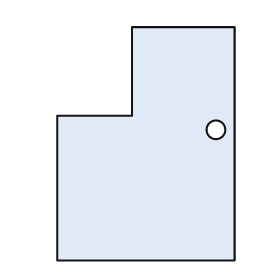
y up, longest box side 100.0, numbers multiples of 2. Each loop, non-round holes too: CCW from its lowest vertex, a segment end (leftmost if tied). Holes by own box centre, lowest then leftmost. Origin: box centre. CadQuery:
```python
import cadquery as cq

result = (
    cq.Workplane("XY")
    .moveTo(-38.0, -50.0)
    .lineTo(38.0, -50.0)
    .lineTo(38.0, 50.0)
    .lineTo(-6.0, 50.0)
    .lineTo(-6.0, 12.0)
    .lineTo(-38.0, 12.0)
    .close()
    .moveTo(30.0, 6.0)
    .circle(4.0)
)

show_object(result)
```